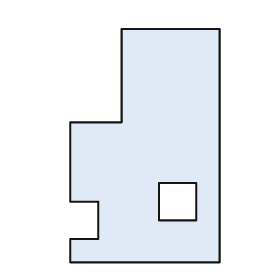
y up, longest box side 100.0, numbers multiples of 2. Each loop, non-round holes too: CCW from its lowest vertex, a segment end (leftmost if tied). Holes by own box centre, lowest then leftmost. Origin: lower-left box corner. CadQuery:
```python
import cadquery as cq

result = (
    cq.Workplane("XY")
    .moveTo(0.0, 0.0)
    .lineTo(64.0, 0.0)
    .lineTo(64.0, 100.0)
    .lineTo(22.0, 100.0)
    .lineTo(22.0, 60.0)
    .lineTo(0.0, 60.0)
    .lineTo(0.0, 26.0)
    .lineTo(12.0, 26.0)
    .lineTo(12.0, 10.0)
    .lineTo(0.0, 10.0)
    .close()
    .moveTo(38.0, 18.0)
    .lineTo(54.0, 18.0)
    .lineTo(54.0, 34.0)
    .lineTo(38.0, 34.0)
    .close()
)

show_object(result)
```